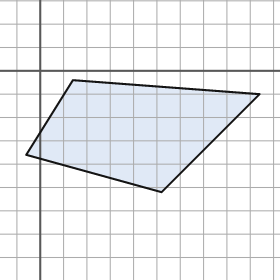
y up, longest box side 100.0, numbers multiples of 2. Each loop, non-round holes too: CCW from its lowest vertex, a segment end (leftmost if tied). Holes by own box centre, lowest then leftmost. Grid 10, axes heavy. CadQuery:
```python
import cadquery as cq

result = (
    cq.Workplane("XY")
    .moveTo(52.0, -52.0)
    .lineTo(94.0, -10.0)
    .lineTo(14.0, -4.0)
    .lineTo(-6.0, -36.0)
    .close()
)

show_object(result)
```